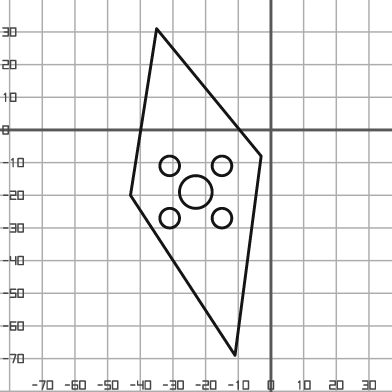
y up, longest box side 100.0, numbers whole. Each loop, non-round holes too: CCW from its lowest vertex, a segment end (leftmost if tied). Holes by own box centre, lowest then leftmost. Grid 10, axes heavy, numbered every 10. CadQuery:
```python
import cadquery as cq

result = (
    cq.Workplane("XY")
    .moveTo(-11.0, -69.0)
    .lineTo(-3.0, -8.0)
    .lineTo(-35.0, 31.0)
    .lineTo(-43.0, -20.0)
    .close()
    .moveTo(-31.0, -27.0)
    .circle(3.0)
    .moveTo(-15.0, -27.0)
    .circle(3.0)
    .moveTo(-23.0, -19.0)
    .circle(5.0)
    .moveTo(-31.0, -11.0)
    .circle(3.0)
    .moveTo(-15.0, -11.0)
    .circle(3.0)
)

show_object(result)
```